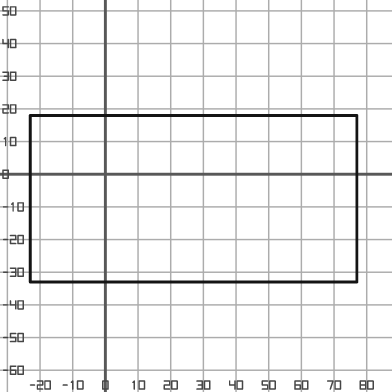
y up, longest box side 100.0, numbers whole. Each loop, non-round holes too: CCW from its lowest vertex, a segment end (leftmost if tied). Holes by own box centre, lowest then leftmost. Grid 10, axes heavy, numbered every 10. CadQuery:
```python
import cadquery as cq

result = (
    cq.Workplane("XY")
    .moveTo(-23.0, -33.0)
    .lineTo(77.0, -33.0)
    .lineTo(77.0, 18.0)
    .lineTo(-23.0, 18.0)
    .close()
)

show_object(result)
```